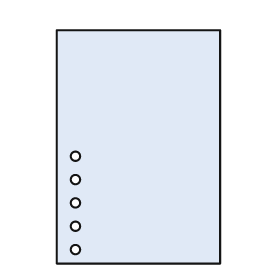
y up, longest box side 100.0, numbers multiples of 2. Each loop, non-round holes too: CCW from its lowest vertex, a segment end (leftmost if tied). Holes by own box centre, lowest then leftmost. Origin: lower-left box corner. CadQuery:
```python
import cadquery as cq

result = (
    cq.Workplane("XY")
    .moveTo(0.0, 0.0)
    .lineTo(70.0, 0.0)
    .lineTo(70.0, 100.0)
    .lineTo(0.0, 100.0)
    .close()
    .moveTo(8.0, 6.0)
    .circle(2.0)
    .moveTo(8.0, 16.0)
    .circle(2.0)
    .moveTo(8.0, 26.0)
    .circle(2.0)
    .moveTo(8.0, 36.0)
    .circle(2.0)
    .moveTo(8.0, 46.0)
    .circle(2.0)
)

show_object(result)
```